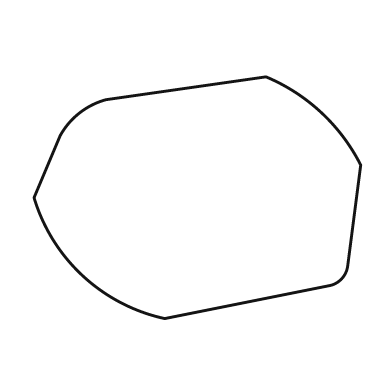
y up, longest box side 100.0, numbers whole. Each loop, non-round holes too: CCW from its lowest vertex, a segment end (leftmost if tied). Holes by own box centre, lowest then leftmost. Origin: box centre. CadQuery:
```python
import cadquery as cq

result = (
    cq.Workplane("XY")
    .moveTo(-10.0, -37.0)
    .lineTo(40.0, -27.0)
    .threePointArc((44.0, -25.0), (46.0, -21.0))
    .lineTo(50.0, 10.0)
    .threePointArc((38.0, 26.0), (21.0, 37.0))
    .lineTo(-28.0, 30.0)
    .threePointArc((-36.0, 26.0), (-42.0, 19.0))
    .lineTo(-50.0, 0.0)
    .threePointArc((-35.0, -24.0), (-10.0, -37.0))
    .close()
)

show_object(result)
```